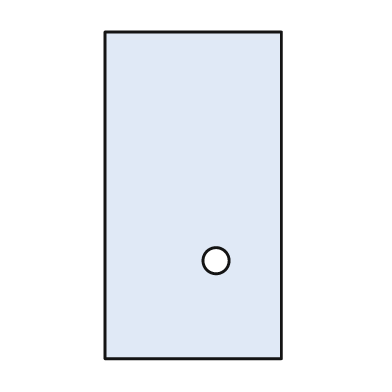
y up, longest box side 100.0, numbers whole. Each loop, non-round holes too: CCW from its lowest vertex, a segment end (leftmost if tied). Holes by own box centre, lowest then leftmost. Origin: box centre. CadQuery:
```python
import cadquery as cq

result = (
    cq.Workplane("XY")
    .moveTo(-27.0, -50.0)
    .lineTo(27.0, -50.0)
    .lineTo(27.0, 50.0)
    .lineTo(-27.0, 50.0)
    .close()
    .moveTo(7.0, -20.0)
    .circle(4.0)
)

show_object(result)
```